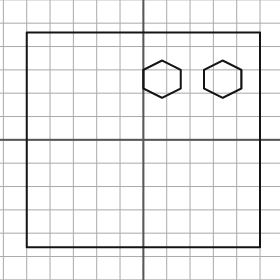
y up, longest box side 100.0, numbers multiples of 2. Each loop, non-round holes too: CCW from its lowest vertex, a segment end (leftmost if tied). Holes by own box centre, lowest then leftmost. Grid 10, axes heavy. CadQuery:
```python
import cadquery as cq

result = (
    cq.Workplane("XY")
    .moveTo(-50.0, -46.0)
    .lineTo(50.0, -46.0)
    .lineTo(50.0, 46.0)
    .lineTo(-50.0, 46.0)
    .close()
    .moveTo(8.0, 18.0)
    .lineTo(16.0, 22.0)
    .lineTo(16.0, 30.0)
    .lineTo(8.0, 34.0)
    .lineTo(0.0, 30.0)
    .lineTo(0.0, 22.0)
    .close()
    .moveTo(34.0, 18.0)
    .lineTo(42.0, 22.0)
    .lineTo(42.0, 30.0)
    .lineTo(34.0, 34.0)
    .lineTo(26.0, 30.0)
    .lineTo(26.0, 22.0)
    .close()
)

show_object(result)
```